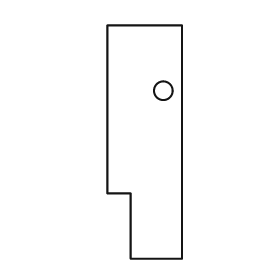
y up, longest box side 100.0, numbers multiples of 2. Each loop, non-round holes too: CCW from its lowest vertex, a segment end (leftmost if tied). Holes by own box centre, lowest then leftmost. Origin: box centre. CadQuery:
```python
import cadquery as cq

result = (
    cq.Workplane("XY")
    .moveTo(-6.0, -50.0)
    .lineTo(16.0, -50.0)
    .lineTo(16.0, 50.0)
    .lineTo(-16.0, 50.0)
    .lineTo(-16.0, -22.0)
    .lineTo(-6.0, -22.0)
    .close()
    .moveTo(8.0, 22.0)
    .circle(4.0)
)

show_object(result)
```